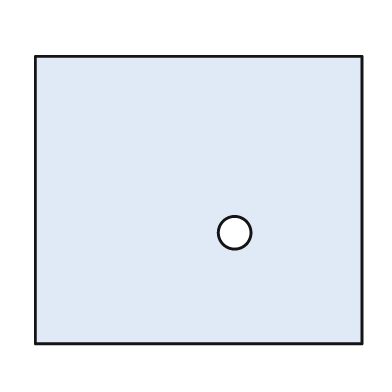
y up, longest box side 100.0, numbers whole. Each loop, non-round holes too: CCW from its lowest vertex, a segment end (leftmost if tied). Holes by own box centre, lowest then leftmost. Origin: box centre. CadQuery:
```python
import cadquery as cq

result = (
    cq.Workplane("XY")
    .moveTo(-50.0, -44.0)
    .lineTo(50.0, -44.0)
    .lineTo(50.0, 44.0)
    .lineTo(-50.0, 44.0)
    .close()
    .moveTo(11.0, -10.0)
    .circle(5.0)
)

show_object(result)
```